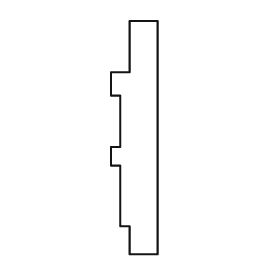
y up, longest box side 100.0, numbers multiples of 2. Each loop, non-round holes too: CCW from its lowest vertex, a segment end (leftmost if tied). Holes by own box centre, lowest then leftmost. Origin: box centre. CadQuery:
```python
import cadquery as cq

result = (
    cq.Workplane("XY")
    .moveTo(-2.0, -50.0)
    .lineTo(10.0, -50.0)
    .lineTo(10.0, 50.0)
    .lineTo(-2.0, 50.0)
    .lineTo(-2.0, 28.0)
    .lineTo(-10.0, 28.0)
    .lineTo(-10.0, 18.0)
    .lineTo(-6.0, 18.0)
    .lineTo(-6.0, -4.0)
    .lineTo(-10.0, -4.0)
    .lineTo(-10.0, -12.0)
    .lineTo(-6.0, -12.0)
    .lineTo(-6.0, -38.0)
    .lineTo(-2.0, -38.0)
    .close()
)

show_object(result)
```